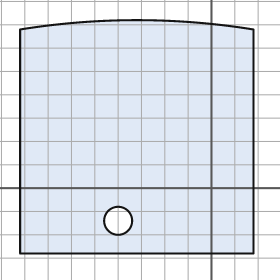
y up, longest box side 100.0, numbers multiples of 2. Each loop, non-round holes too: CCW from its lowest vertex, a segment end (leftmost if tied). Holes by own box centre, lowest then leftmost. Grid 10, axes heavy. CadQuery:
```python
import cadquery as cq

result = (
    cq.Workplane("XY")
    .moveTo(-82.0, -28.0)
    .lineTo(18.0, -28.0)
    .lineTo(18.0, 68.0)
    .threePointArc((-32.0, 72.0), (-82.0, 68.0))
    .close()
    .moveTo(-40.0, -14.0)
    .circle(6.0)
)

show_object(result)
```